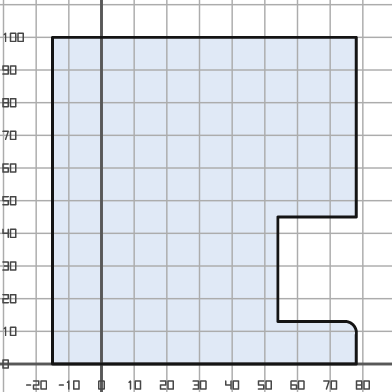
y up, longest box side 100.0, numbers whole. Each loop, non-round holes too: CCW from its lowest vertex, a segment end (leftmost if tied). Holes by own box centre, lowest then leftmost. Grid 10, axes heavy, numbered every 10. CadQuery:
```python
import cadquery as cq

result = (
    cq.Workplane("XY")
    .moveTo(-15.0, 0.0)
    .lineTo(78.0, 0.0)
    .lineTo(78.0, 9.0)
    .threePointArc((77.0, 12.0), (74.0, 13.0))
    .lineTo(54.0, 13.0)
    .lineTo(54.0, 45.0)
    .lineTo(78.0, 45.0)
    .lineTo(78.0, 100.0)
    .lineTo(-15.0, 100.0)
    .close()
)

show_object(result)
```